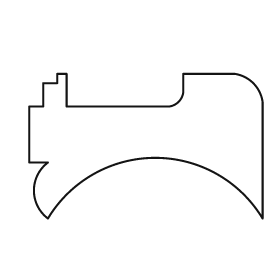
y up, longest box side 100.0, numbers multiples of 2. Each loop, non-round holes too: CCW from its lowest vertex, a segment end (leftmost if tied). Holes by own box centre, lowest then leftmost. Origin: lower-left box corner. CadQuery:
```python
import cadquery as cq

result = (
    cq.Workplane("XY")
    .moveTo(8.0, 0.0)
    .threePointArc((54.0, 26.0), (100.0, 0.0))
    .lineTo(100.0, 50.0)
    .threePointArc((96.0, 58.0), (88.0, 62.0))
    .lineTo(66.0, 62.0)
    .lineTo(66.0, 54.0)
    .threePointArc((64.0, 50.0), (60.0, 48.0))
    .lineTo(16.0, 48.0)
    .lineTo(16.0, 62.0)
    .lineTo(12.0, 62.0)
    .lineTo(12.0, 58.0)
    .lineTo(6.0, 58.0)
    .lineTo(6.0, 48.0)
    .lineTo(0.0, 48.0)
    .lineTo(0.0, 24.0)
    .lineTo(8.0, 24.0)
    .threePointArc((2.0, 12.0), (8.0, 0.0))
    .close()
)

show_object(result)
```